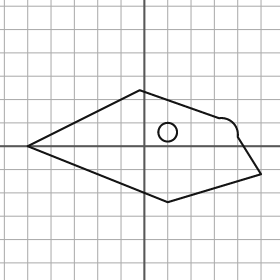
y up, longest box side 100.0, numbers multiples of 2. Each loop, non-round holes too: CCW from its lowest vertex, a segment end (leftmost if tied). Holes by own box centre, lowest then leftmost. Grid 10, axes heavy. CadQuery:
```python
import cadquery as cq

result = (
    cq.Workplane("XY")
    .moveTo(10.0, -24.0)
    .lineTo(50.0, -12.0)
    .lineTo(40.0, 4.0)
    .threePointArc((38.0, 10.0), (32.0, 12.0))
    .lineTo(-2.0, 24.0)
    .lineTo(-50.0, 0.0)
    .close()
    .moveTo(10.0, 6.0)
    .circle(4.0)
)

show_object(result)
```